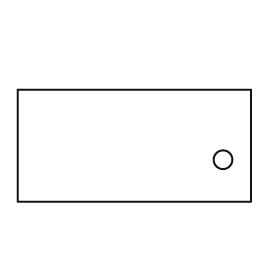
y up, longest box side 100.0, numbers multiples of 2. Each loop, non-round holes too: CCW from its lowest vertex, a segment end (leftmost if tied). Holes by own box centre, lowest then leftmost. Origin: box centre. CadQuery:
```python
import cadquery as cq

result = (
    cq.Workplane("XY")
    .moveTo(-50.0, -24.0)
    .lineTo(50.0, -24.0)
    .lineTo(50.0, 24.0)
    .lineTo(-50.0, 24.0)
    .close()
    .moveTo(38.0, -6.0)
    .circle(4.0)
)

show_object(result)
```